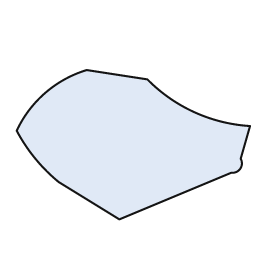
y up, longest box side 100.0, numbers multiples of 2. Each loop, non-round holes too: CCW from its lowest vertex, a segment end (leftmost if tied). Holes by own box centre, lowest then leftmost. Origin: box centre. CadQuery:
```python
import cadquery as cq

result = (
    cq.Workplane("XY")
    .moveTo(-6.0, -32.0)
    .lineTo(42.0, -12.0)
    .threePointArc((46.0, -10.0), (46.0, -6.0))
    .lineTo(50.0, 8.0)
    .threePointArc((26.0, 14.0), (6.0, 28.0))
    .lineTo(-20.0, 32.0)
    .threePointArc((-38.0, 22.0), (-50.0, 6.0))
    .threePointArc((-42.0, -6.0), (-32.0, -16.0))
    .close()
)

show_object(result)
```